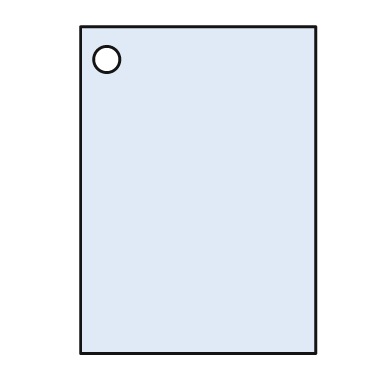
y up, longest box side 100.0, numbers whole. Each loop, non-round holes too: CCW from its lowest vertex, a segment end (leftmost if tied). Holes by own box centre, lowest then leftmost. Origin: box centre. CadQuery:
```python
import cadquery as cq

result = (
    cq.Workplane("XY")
    .moveTo(-36.0, -50.0)
    .lineTo(36.0, -50.0)
    .lineTo(36.0, 50.0)
    .lineTo(-36.0, 50.0)
    .close()
    .moveTo(-28.0, 40.0)
    .circle(4.0)
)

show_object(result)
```